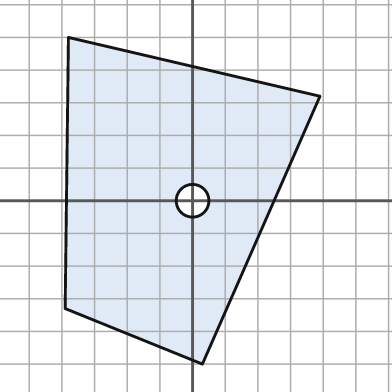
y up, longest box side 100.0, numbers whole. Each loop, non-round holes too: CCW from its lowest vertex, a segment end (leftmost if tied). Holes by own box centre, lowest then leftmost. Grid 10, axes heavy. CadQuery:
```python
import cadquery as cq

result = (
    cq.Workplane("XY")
    .moveTo(3.0, -50.0)
    .lineTo(39.0, 32.0)
    .lineTo(-38.0, 50.0)
    .lineTo(-39.0, -33.0)
    .close()
    .moveTo(0.0, 0.0)
    .circle(5.0)
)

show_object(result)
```